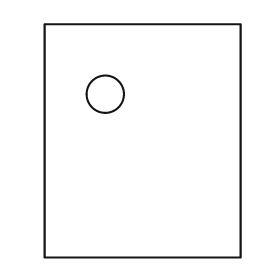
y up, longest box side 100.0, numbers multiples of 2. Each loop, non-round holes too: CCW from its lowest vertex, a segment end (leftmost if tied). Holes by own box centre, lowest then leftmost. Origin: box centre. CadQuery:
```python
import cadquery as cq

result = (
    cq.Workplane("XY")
    .moveTo(-42.0, -50.0)
    .lineTo(42.0, -50.0)
    .lineTo(42.0, 50.0)
    .lineTo(-42.0, 50.0)
    .close()
    .moveTo(-16.0, 20.0)
    .circle(8.0)
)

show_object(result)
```